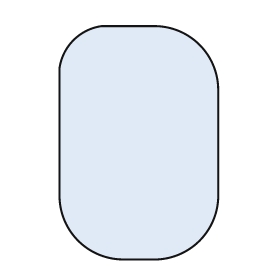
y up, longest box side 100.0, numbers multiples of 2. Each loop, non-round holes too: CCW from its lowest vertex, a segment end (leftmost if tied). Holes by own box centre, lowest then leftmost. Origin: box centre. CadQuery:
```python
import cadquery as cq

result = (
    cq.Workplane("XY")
    .moveTo(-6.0, -50.0)
    .lineTo(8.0, -50.0)
    .threePointArc((26.0, -42.0), (34.0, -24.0))
    .lineTo(34.0, 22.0)
    .threePointArc((26.0, 42.0), (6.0, 50.0))
    .lineTo(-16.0, 50.0)
    .threePointArc((-28.0, 44.0), (-34.0, 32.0))
    .lineTo(-34.0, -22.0)
    .threePointArc((-26.0, -42.0), (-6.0, -50.0))
    .close()
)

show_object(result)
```